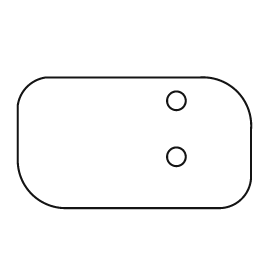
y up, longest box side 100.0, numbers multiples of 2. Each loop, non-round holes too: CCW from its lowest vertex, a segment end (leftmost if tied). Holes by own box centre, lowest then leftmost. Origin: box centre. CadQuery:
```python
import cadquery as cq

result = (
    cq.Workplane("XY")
    .moveTo(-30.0, -28.0)
    .lineTo(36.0, -28.0)
    .threePointArc((46.0, -24.0), (50.0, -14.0))
    .lineTo(50.0, 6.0)
    .threePointArc((44.0, 22.0), (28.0, 28.0))
    .lineTo(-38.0, 28.0)
    .threePointArc((-46.0, 24.0), (-50.0, 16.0))
    .lineTo(-50.0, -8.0)
    .threePointArc((-44.0, -22.0), (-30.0, -28.0))
    .close()
    .moveTo(18.0, -6.0)
    .circle(4.0)
    .moveTo(18.0, 18.0)
    .circle(4.0)
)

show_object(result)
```